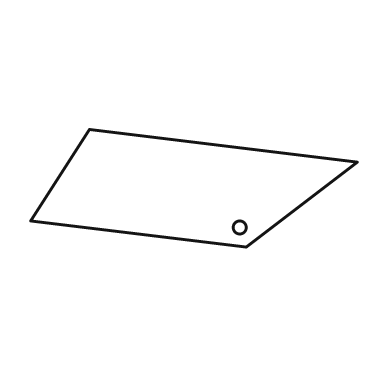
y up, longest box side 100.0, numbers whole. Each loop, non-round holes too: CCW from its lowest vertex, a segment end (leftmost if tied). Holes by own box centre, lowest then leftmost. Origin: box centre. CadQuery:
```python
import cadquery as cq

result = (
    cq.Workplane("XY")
    .moveTo(16.0, -18.0)
    .lineTo(50.0, 8.0)
    .lineTo(-32.0, 18.0)
    .lineTo(-50.0, -10.0)
    .close()
    .moveTo(14.0, -12.0)
    .circle(2.0)
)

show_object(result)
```